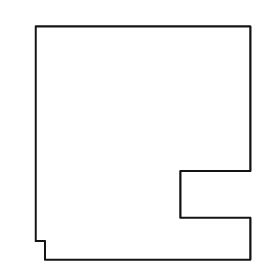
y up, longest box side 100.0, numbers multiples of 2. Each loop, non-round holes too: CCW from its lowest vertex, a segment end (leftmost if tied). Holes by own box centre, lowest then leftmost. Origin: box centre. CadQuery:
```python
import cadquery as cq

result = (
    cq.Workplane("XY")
    .moveTo(-42.0, -50.0)
    .lineTo(46.0, -50.0)
    .lineTo(46.0, -32.0)
    .lineTo(16.0, -32.0)
    .lineTo(16.0, -12.0)
    .lineTo(46.0, -12.0)
    .lineTo(46.0, 50.0)
    .lineTo(-46.0, 50.0)
    .lineTo(-46.0, -42.0)
    .lineTo(-42.0, -42.0)
    .close()
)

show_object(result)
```